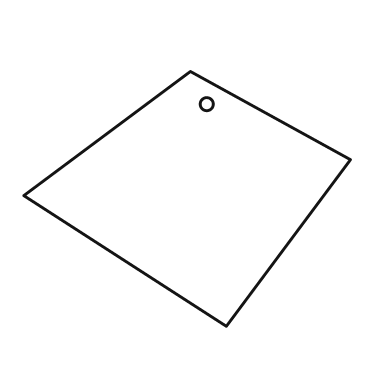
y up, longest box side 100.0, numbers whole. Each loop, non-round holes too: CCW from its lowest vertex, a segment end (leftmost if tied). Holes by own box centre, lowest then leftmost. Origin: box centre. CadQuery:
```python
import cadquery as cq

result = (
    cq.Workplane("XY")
    .moveTo(12.0, -39.0)
    .lineTo(50.0, 12.0)
    .lineTo(1.0, 39.0)
    .lineTo(-50.0, 1.0)
    .close()
    .moveTo(6.0, 29.0)
    .circle(2.0)
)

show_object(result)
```